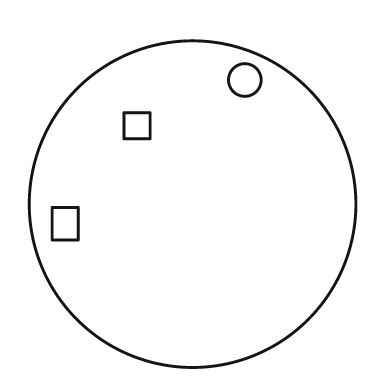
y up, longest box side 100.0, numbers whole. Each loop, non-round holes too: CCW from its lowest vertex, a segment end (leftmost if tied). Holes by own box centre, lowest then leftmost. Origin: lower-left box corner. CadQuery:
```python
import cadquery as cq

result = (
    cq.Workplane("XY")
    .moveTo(50.0, 50.0)
    .circle(50.0)
    .moveTo(7.0, 39.0)
    .lineTo(15.0, 39.0)
    .lineTo(15.0, 49.0)
    .lineTo(7.0, 49.0)
    .close()
    .moveTo(29.0, 70.0)
    .lineTo(37.0, 70.0)
    .lineTo(37.0, 78.0)
    .lineTo(29.0, 78.0)
    .close()
    .moveTo(66.0, 88.0)
    .circle(5.0)
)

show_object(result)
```